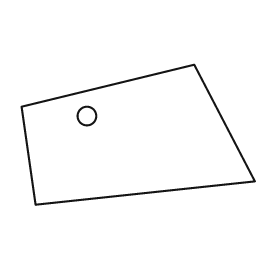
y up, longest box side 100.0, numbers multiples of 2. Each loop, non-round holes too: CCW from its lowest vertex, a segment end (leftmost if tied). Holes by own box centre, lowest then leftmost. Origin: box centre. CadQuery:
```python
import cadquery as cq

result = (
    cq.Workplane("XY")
    .moveTo(-44.0, -30.0)
    .lineTo(50.0, -20.0)
    .lineTo(24.0, 30.0)
    .lineTo(-50.0, 12.0)
    .close()
    .moveTo(-22.0, 8.0)
    .circle(4.0)
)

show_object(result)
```